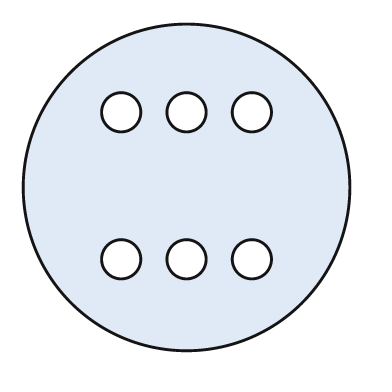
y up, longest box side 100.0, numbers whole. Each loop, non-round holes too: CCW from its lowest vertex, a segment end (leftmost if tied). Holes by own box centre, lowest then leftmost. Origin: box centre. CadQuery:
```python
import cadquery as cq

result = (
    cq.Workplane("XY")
    .moveTo(0.0, 0.0)
    .circle(50.0)
    .moveTo(-20.0, -22.0)
    .circle(6.0)
    .moveTo(0.0, -22.0)
    .circle(6.0)
    .moveTo(20.0, -22.0)
    .circle(6.0)
    .moveTo(-20.0, 23.0)
    .circle(6.0)
    .moveTo(0.0, 23.0)
    .circle(6.0)
    .moveTo(20.0, 23.0)
    .circle(6.0)
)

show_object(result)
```